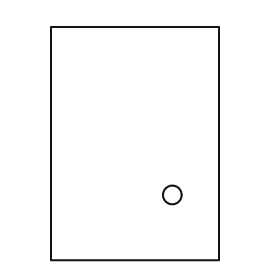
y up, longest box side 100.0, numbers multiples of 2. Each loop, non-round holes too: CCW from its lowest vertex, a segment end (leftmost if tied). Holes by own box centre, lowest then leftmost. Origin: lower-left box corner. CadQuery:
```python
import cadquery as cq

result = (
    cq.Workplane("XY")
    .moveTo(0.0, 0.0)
    .lineTo(72.0, 0.0)
    .lineTo(72.0, 100.0)
    .lineTo(0.0, 100.0)
    .close()
    .moveTo(52.0, 28.0)
    .circle(4.0)
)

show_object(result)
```